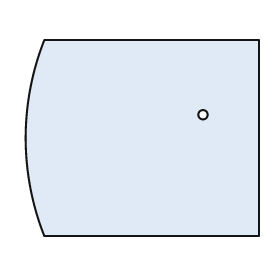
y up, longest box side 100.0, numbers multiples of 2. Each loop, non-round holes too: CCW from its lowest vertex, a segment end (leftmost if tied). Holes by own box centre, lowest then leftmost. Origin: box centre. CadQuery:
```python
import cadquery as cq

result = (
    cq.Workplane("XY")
    .moveTo(-42.0, -42.0)
    .lineTo(50.0, -42.0)
    .lineTo(50.0, 42.0)
    .lineTo(-42.0, 42.0)
    .threePointArc((-50.0, 0.0), (-42.0, -42.0))
    .close()
    .moveTo(26.0, 10.0)
    .circle(2.0)
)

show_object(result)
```